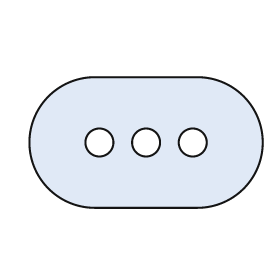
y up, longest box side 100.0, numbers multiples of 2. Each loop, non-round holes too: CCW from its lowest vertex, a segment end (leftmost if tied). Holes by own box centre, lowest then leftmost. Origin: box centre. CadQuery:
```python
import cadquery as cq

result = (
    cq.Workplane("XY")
    .moveTo(-22.0, -28.0)
    .lineTo(22.0, -28.0)
    .threePointArc((50.0, 0.0), (22.0, 28.0))
    .lineTo(-22.0, 28.0)
    .threePointArc((-50.0, 0.0), (-22.0, -28.0))
    .close()
    .moveTo(-20.0, 0.0)
    .circle(6.0)
    .moveTo(0.0, 0.0)
    .circle(6.0)
    .moveTo(20.0, 0.0)
    .circle(6.0)
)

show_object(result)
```